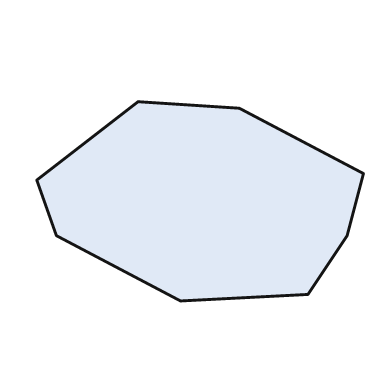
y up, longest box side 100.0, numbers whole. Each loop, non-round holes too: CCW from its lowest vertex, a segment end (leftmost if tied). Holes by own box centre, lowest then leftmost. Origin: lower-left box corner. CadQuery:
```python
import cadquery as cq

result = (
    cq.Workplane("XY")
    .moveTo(44.0, 0.0)
    .lineTo(83.0, 2.0)
    .lineTo(95.0, 20.0)
    .lineTo(100.0, 39.0)
    .lineTo(62.0, 59.0)
    .lineTo(31.0, 61.0)
    .lineTo(0.0, 37.0)
    .lineTo(6.0, 20.0)
    .close()
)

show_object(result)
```